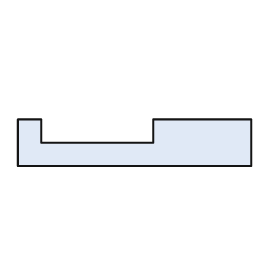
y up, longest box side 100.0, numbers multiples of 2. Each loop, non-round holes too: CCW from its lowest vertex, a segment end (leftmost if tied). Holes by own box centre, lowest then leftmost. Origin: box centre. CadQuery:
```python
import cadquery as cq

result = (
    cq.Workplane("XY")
    .moveTo(-50.0, -10.0)
    .lineTo(50.0, -10.0)
    .lineTo(50.0, 10.0)
    .lineTo(8.0, 10.0)
    .lineTo(8.0, 0.0)
    .lineTo(-40.0, 0.0)
    .lineTo(-40.0, 10.0)
    .lineTo(-50.0, 10.0)
    .close()
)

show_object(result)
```